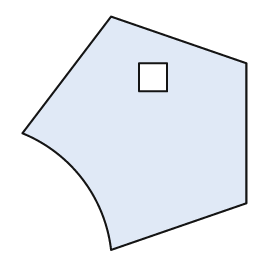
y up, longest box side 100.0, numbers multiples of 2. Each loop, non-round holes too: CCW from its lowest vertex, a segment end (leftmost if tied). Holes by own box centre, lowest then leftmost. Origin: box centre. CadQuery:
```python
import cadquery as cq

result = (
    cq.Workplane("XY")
    .moveTo(-10.0, -50.0)
    .lineTo(48.0, -30.0)
    .lineTo(48.0, 30.0)
    .lineTo(-10.0, 50.0)
    .lineTo(-48.0, 0.0)
    .threePointArc((-22.0, -20.0), (-10.0, -50.0))
    .close()
    .moveTo(2.0, 18.0)
    .lineTo(14.0, 18.0)
    .lineTo(14.0, 30.0)
    .lineTo(2.0, 30.0)
    .close()
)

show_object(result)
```